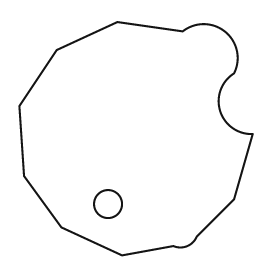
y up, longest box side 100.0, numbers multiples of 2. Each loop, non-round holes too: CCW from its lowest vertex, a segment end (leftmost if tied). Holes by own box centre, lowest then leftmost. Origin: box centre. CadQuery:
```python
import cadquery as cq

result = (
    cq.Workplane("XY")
    .moveTo(-6.0, -50.0)
    .lineTo(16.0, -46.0)
    .threePointArc((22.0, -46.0), (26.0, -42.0))
    .lineTo(42.0, -26.0)
    .lineTo(50.0, 2.0)
    .threePointArc((36.0, 12.0), (42.0, 28.0))
    .threePointArc((38.0, 46.0), (20.0, 46.0))
    .lineTo(-8.0, 50.0)
    .lineTo(-34.0, 38.0)
    .lineTo(-50.0, 14.0)
    .lineTo(-48.0, -16.0)
    .lineTo(-32.0, -38.0)
    .close()
    .moveTo(-12.0, -28.0)
    .circle(6.0)
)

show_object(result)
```